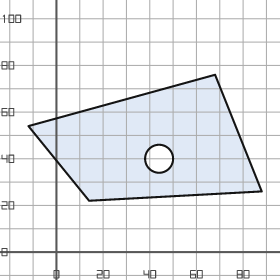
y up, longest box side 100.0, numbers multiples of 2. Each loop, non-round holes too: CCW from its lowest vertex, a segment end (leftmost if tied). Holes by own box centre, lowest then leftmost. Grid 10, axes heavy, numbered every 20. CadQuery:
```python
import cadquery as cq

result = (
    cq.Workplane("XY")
    .moveTo(14.0, 22.0)
    .lineTo(88.0, 26.0)
    .lineTo(68.0, 76.0)
    .lineTo(-12.0, 54.0)
    .close()
    .moveTo(44.0, 40.0)
    .circle(6.0)
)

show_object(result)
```